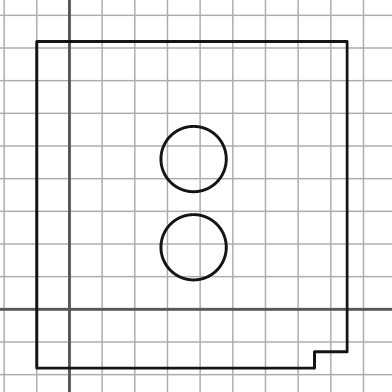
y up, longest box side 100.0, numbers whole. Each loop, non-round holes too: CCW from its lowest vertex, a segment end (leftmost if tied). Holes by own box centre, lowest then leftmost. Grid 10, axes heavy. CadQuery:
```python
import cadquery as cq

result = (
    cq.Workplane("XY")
    .moveTo(-10.0, -18.0)
    .lineTo(75.0, -18.0)
    .lineTo(75.0, -13.0)
    .lineTo(85.0, -13.0)
    .lineTo(85.0, 82.0)
    .lineTo(-10.0, 82.0)
    .close()
    .moveTo(38.0, 19.0)
    .circle(10.0)
    .moveTo(38.0, 46.0)
    .circle(10.0)
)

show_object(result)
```